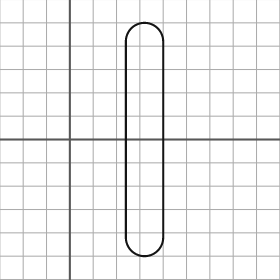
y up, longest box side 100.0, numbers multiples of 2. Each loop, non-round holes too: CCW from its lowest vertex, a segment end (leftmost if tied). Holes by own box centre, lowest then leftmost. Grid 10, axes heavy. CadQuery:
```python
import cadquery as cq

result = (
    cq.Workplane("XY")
    .moveTo(24.0, -42.0)
    .threePointArc((32.0, -50.0), (40.0, -42.0))
    .lineTo(40.0, 42.0)
    .threePointArc((32.0, 50.0), (24.0, 42.0))
    .close()
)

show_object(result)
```